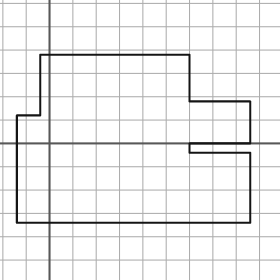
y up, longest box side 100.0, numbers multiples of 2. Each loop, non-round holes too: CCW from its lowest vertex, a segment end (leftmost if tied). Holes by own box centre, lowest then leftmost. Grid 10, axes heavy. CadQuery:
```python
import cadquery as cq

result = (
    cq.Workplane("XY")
    .moveTo(-14.0, -34.0)
    .lineTo(86.0, -34.0)
    .lineTo(86.0, -4.0)
    .lineTo(60.0, -4.0)
    .lineTo(60.0, 0.0)
    .lineTo(86.0, 0.0)
    .lineTo(86.0, 18.0)
    .lineTo(60.0, 18.0)
    .lineTo(60.0, 38.0)
    .lineTo(-4.0, 38.0)
    .lineTo(-4.0, 12.0)
    .lineTo(-14.0, 12.0)
    .close()
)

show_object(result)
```